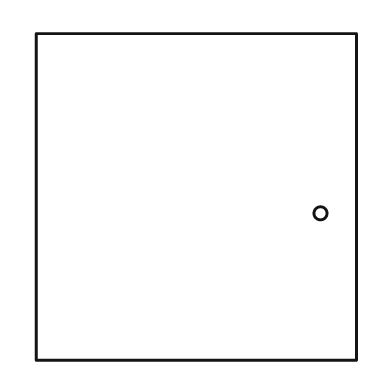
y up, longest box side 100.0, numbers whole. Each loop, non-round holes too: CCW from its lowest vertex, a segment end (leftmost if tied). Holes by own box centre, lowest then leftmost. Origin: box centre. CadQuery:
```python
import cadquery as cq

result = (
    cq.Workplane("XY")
    .moveTo(-49.0, -50.0)
    .lineTo(49.0, -50.0)
    .lineTo(49.0, 50.0)
    .lineTo(-49.0, 50.0)
    .close()
    .moveTo(38.0, -5.0)
    .circle(2.0)
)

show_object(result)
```